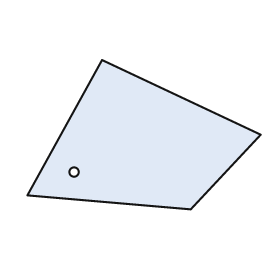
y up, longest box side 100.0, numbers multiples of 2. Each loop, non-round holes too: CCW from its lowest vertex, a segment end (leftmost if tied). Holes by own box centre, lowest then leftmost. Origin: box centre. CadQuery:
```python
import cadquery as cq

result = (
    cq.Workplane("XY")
    .moveTo(20.0, -32.0)
    .lineTo(50.0, 0.0)
    .lineTo(-18.0, 32.0)
    .lineTo(-50.0, -26.0)
    .close()
    .moveTo(-30.0, -16.0)
    .circle(2.0)
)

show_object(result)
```